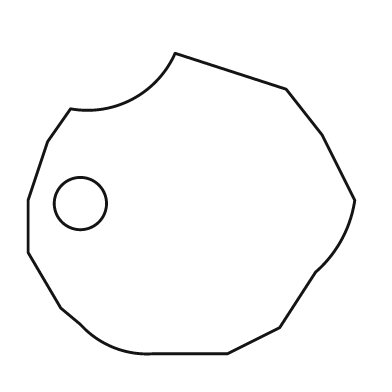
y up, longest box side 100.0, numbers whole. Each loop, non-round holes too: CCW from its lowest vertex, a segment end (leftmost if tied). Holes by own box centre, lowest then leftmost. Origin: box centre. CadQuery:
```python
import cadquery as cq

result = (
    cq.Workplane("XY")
    .moveTo(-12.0, -46.0)
    .lineTo(11.0, -46.0)
    .lineTo(27.0, -38.0)
    .lineTo(38.0, -21.0)
    .threePointArc((46.0, -11.0), (50.0, 1.0))
    .lineTo(40.0, 21.0)
    .lineTo(29.0, 35.0)
    .lineTo(-5.0, 46.0)
    .threePointArc((-18.0, 32.0), (-37.0, 29.0))
    .lineTo(-44.0, 19.0)
    .lineTo(-50.0, 1.0)
    .lineTo(-50.0, -15.0)
    .lineTo(-40.0, -32.0)
    .lineTo(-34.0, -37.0)
    .threePointArc((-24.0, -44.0), (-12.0, -46.0))
    .close()
    .moveTo(-34.0, 0.0)
    .circle(8.0)
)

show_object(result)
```